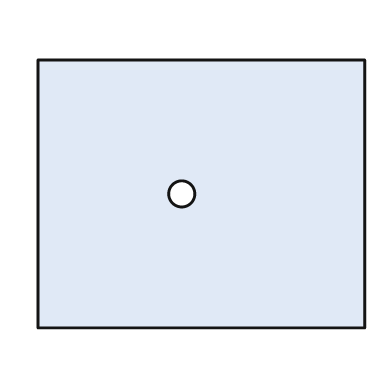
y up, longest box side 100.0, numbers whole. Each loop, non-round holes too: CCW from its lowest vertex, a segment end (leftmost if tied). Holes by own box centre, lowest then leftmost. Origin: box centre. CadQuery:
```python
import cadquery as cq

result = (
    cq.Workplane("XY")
    .moveTo(-50.0, -41.0)
    .lineTo(50.0, -41.0)
    .lineTo(50.0, 41.0)
    .lineTo(-50.0, 41.0)
    .close()
    .moveTo(-6.0, 0.0)
    .circle(4.0)
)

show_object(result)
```